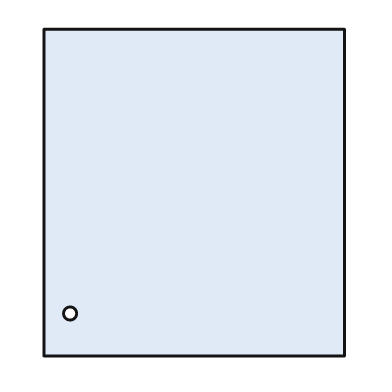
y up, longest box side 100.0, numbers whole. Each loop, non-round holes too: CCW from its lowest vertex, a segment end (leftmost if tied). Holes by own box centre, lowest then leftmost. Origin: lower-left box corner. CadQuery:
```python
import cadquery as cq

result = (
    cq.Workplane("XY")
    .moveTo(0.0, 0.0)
    .lineTo(92.0, 0.0)
    .lineTo(92.0, 100.0)
    .lineTo(0.0, 100.0)
    .close()
    .moveTo(8.0, 13.0)
    .circle(2.0)
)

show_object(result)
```